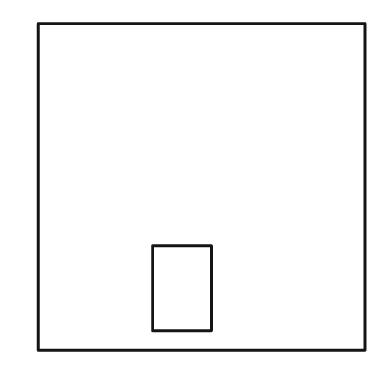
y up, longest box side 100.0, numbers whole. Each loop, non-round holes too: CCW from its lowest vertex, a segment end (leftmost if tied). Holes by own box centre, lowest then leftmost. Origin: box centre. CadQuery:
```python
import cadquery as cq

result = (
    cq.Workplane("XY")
    .moveTo(-50.0, -50.0)
    .lineTo(50.0, -50.0)
    .lineTo(50.0, 50.0)
    .lineTo(-50.0, 50.0)
    .close()
    .moveTo(-15.0, -44.0)
    .lineTo(3.0, -44.0)
    .lineTo(3.0, -18.0)
    .lineTo(-15.0, -18.0)
    .close()
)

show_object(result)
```